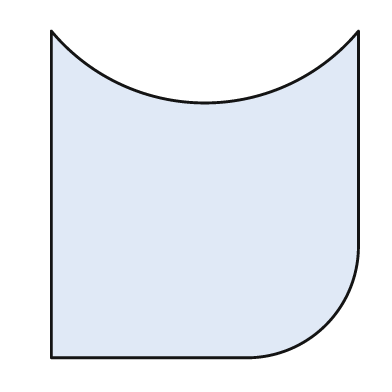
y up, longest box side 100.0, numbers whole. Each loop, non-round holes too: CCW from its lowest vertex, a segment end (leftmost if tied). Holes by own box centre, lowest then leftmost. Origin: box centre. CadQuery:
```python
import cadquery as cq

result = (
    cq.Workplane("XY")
    .moveTo(-47.0, -50.0)
    .lineTo(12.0, -50.0)
    .threePointArc((37.0, -40.0), (47.0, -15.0))
    .lineTo(47.0, 50.0)
    .threePointArc((0.0, 28.0), (-47.0, 50.0))
    .close()
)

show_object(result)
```